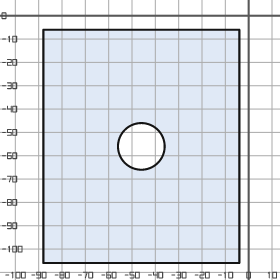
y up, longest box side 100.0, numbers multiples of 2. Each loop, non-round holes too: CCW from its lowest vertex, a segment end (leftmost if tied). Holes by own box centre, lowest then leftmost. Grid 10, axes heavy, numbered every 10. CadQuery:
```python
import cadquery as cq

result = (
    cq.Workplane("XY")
    .moveTo(-88.0, -106.0)
    .lineTo(-4.0, -106.0)
    .lineTo(-4.0, -6.0)
    .lineTo(-88.0, -6.0)
    .close()
    .moveTo(-46.0, -56.0)
    .circle(10.0)
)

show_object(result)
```